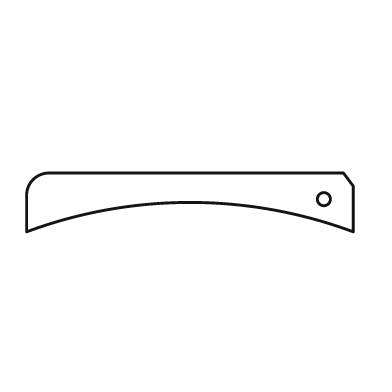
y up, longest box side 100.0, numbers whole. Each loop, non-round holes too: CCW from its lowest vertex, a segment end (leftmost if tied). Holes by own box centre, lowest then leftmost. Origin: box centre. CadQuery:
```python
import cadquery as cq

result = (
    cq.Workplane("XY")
    .moveTo(-50.0, -9.0)
    .threePointArc((0.0, 0.0), (50.0, -9.0))
    .lineTo(50.0, 5.0)
    .lineTo(47.0, 9.0)
    .lineTo(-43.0, 9.0)
    .threePointArc((-48.0, 7.0), (-50.0, 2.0))
    .close()
    .moveTo(41.0, 1.0)
    .circle(2.0)
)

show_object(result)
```